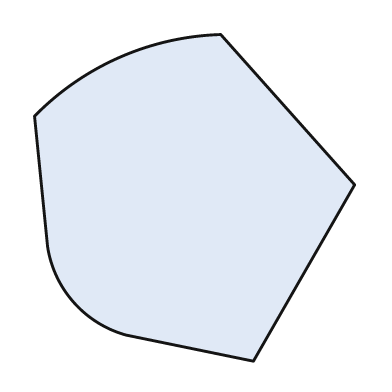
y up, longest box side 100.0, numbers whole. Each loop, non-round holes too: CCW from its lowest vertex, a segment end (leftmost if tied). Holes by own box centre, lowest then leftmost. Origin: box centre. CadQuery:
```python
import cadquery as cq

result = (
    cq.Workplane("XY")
    .moveTo(18.0, -50.0)
    .lineTo(49.0, 4.0)
    .lineTo(8.0, 50.0)
    .threePointArc((-23.0, 43.0), (-49.0, 25.0))
    .lineTo(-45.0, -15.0)
    .threePointArc((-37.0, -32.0), (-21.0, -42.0))
    .close()
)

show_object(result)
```